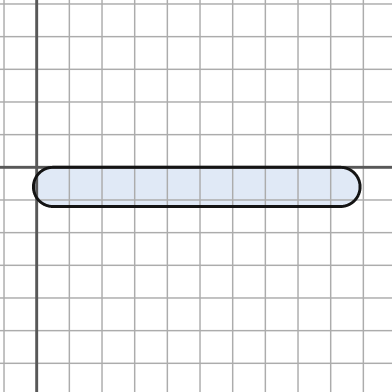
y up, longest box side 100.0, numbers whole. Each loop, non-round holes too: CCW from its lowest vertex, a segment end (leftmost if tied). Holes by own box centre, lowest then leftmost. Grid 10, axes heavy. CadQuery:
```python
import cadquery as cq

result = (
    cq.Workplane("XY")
    .moveTo(5.0, -12.0)
    .lineTo(93.0, -12.0)
    .threePointArc((99.0, -6.0), (93.0, 0.0))
    .lineTo(5.0, 0.0)
    .threePointArc((-1.0, -6.0), (5.0, -12.0))
    .close()
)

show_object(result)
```